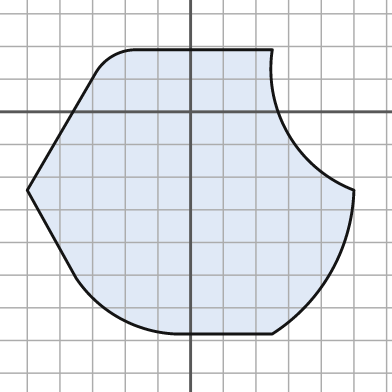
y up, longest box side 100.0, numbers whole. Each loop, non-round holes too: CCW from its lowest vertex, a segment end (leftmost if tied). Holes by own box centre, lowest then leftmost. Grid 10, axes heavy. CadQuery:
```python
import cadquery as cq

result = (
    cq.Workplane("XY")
    .moveTo(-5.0, -68.0)
    .lineTo(25.0, -68.0)
    .threePointArc((43.0, -49.0), (50.0, -24.0))
    .threePointArc((30.0, -7.0), (25.0, 19.0))
    .lineTo(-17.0, 19.0)
    .threePointArc((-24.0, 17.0), (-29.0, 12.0))
    .lineTo(-50.0, -24.0)
    .lineTo(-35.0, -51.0)
    .threePointArc((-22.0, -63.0), (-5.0, -68.0))
    .close()
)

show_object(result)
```